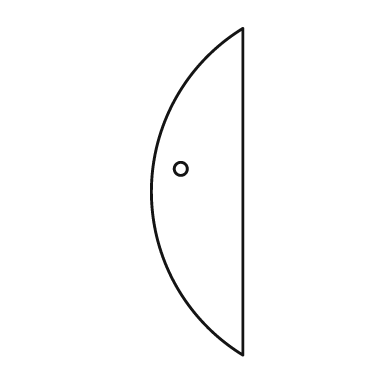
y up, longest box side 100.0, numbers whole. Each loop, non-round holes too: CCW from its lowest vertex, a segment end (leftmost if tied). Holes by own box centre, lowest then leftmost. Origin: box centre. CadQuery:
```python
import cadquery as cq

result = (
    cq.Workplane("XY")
    .moveTo(14.0, -50.0)
    .lineTo(14.0, 50.0)
    .threePointArc((-14.0, 0.0), (14.0, -50.0))
    .close()
    .moveTo(-5.0, 7.0)
    .circle(2.0)
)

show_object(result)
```